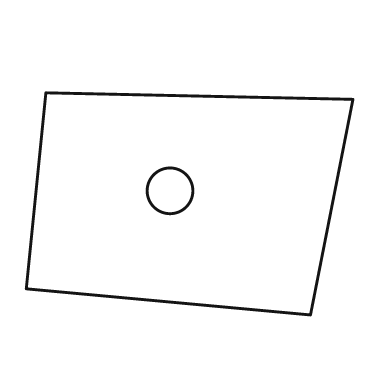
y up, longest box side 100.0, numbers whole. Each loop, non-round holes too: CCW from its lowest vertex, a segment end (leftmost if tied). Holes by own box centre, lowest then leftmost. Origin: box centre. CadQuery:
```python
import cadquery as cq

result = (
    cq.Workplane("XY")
    .moveTo(37.0, -34.0)
    .lineTo(50.0, 32.0)
    .lineTo(-44.0, 34.0)
    .lineTo(-50.0, -26.0)
    .close()
    .moveTo(-6.0, 4.0)
    .circle(7.0)
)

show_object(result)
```